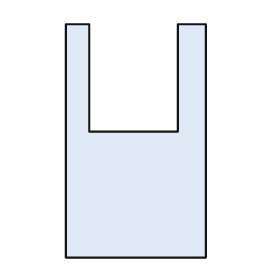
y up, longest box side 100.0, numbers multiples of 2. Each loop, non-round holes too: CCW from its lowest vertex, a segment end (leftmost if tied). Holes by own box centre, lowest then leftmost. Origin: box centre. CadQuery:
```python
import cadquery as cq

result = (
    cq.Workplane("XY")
    .moveTo(-30.0, -50.0)
    .lineTo(30.0, -50.0)
    .lineTo(30.0, 50.0)
    .lineTo(18.0, 50.0)
    .lineTo(18.0, 4.0)
    .lineTo(-20.0, 4.0)
    .lineTo(-20.0, 50.0)
    .lineTo(-30.0, 50.0)
    .close()
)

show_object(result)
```